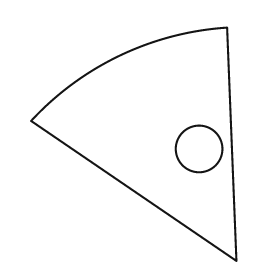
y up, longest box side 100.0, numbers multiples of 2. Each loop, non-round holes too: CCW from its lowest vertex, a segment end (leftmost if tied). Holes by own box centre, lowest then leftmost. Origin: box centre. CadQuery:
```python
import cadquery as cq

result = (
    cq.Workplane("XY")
    .moveTo(44.0, -50.0)
    .lineTo(40.0, 50.0)
    .threePointArc((-6.0, 38.0), (-44.0, 10.0))
    .close()
    .moveTo(28.0, -2.0)
    .circle(10.0)
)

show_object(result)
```